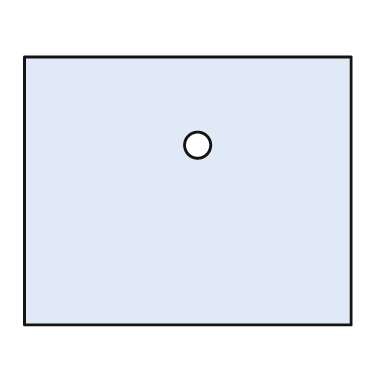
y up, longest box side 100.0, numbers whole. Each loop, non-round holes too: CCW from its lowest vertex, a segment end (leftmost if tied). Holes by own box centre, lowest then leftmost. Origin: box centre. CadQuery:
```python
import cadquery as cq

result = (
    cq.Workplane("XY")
    .moveTo(-50.0, -41.0)
    .lineTo(50.0, -41.0)
    .lineTo(50.0, 41.0)
    .lineTo(-50.0, 41.0)
    .close()
    .moveTo(3.0, 14.0)
    .circle(4.0)
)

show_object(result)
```